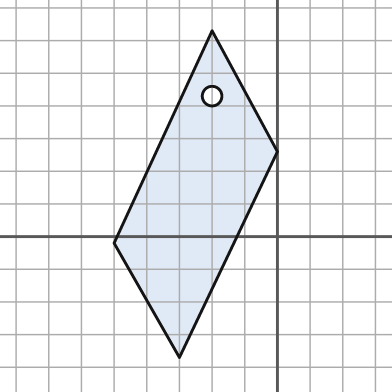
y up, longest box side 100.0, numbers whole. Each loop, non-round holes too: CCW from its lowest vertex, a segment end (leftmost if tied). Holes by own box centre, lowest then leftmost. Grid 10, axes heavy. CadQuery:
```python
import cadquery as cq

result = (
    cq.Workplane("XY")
    .moveTo(-30.0, -37.0)
    .lineTo(0.0, 26.0)
    .lineTo(-20.0, 63.0)
    .lineTo(-50.0, -2.0)
    .close()
    .moveTo(-20.0, 43.0)
    .circle(3.0)
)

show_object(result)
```